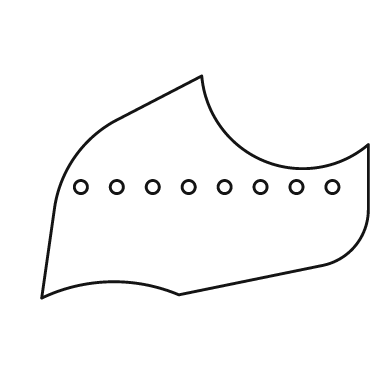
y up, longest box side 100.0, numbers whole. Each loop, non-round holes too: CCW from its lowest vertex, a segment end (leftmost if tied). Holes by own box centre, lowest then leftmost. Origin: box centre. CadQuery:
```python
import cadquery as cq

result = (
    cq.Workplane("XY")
    .moveTo(-50.0, -34.0)
    .threePointArc((-29.0, -29.0), (-8.0, -33.0))
    .lineTo(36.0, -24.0)
    .threePointArc((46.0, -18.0), (50.0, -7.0))
    .lineTo(50.0, 13.0)
    .threePointArc((18.0, 8.0), (-1.0, 34.0))
    .lineTo(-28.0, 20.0)
    .threePointArc((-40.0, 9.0), (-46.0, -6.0))
    .close()
    .moveTo(-38.0, 0.0)
    .circle(2.0)
    .moveTo(-27.0, 0.0)
    .circle(2.0)
    .moveTo(-16.0, 0.0)
    .circle(2.0)
    .moveTo(-5.0, 0.0)
    .circle(2.0)
    .moveTo(6.0, 0.0)
    .circle(2.0)
    .moveTo(17.0, 0.0)
    .circle(2.0)
    .moveTo(28.0, 0.0)
    .circle(2.0)
    .moveTo(39.0, 0.0)
    .circle(2.0)
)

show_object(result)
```